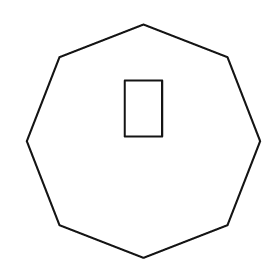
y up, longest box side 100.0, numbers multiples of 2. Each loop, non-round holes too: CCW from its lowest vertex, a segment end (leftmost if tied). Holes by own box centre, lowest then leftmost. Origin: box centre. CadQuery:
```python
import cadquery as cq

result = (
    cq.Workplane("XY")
    .moveTo(0.0, -50.0)
    .lineTo(36.0, -36.0)
    .lineTo(50.0, 0.0)
    .lineTo(36.0, 36.0)
    .lineTo(0.0, 50.0)
    .lineTo(-36.0, 36.0)
    .lineTo(-50.0, 0.0)
    .lineTo(-36.0, -36.0)
    .close()
    .moveTo(-8.0, 2.0)
    .lineTo(8.0, 2.0)
    .lineTo(8.0, 26.0)
    .lineTo(-8.0, 26.0)
    .close()
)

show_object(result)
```